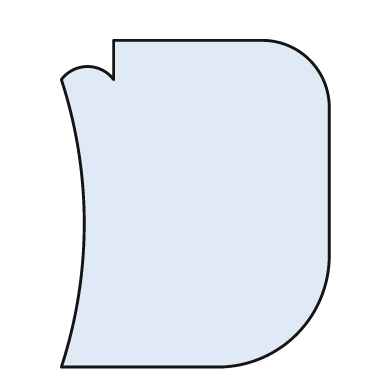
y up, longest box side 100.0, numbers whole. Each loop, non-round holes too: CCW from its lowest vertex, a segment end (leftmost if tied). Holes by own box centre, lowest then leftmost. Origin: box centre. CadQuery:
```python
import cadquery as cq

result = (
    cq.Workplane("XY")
    .moveTo(-41.0, -50.0)
    .lineTo(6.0, -50.0)
    .threePointArc((31.0, -40.0), (41.0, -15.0))
    .lineTo(41.0, 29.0)
    .threePointArc((35.0, 44.0), (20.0, 50.0))
    .lineTo(-25.0, 50.0)
    .lineTo(-25.0, 38.0)
    .threePointArc((-33.0, 42.0), (-41.0, 38.0))
    .threePointArc((-34.0, -6.0), (-41.0, -50.0))
    .close()
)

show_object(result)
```